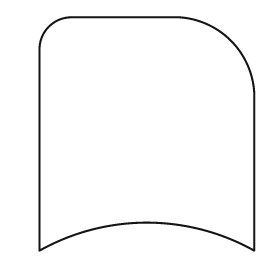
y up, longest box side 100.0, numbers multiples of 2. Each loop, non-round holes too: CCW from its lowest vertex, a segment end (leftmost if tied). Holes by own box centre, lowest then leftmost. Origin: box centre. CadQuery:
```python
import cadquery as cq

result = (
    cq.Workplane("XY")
    .moveTo(-46.0, -50.0)
    .threePointArc((0.0, -38.0), (46.0, -50.0))
    .lineTo(46.0, 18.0)
    .threePointArc((36.0, 40.0), (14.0, 50.0))
    .lineTo(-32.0, 50.0)
    .threePointArc((-42.0, 46.0), (-46.0, 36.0))
    .close()
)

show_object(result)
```